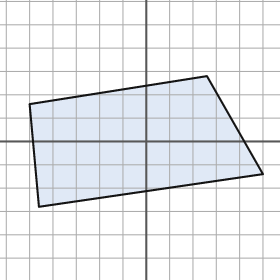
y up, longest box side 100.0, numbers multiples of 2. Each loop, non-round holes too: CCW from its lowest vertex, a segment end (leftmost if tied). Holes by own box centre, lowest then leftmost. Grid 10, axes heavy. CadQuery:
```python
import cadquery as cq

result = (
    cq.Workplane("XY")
    .moveTo(-46.0, -28.0)
    .lineTo(50.0, -14.0)
    .lineTo(26.0, 28.0)
    .lineTo(-50.0, 16.0)
    .close()
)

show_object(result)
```